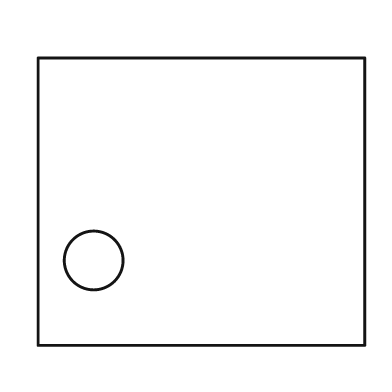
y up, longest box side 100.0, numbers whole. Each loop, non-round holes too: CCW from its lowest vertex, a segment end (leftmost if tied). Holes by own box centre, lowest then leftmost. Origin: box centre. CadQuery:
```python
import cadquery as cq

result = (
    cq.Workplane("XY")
    .moveTo(-50.0, -44.0)
    .lineTo(50.0, -44.0)
    .lineTo(50.0, 44.0)
    .lineTo(-50.0, 44.0)
    .close()
    .moveTo(-33.0, -18.0)
    .circle(9.0)
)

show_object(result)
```